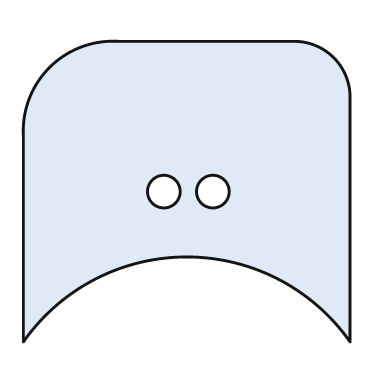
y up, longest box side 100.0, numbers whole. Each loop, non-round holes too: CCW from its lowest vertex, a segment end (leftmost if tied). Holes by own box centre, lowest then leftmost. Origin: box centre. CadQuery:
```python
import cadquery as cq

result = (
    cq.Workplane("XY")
    .moveTo(-50.0, -46.0)
    .threePointArc((0.0, -20.0), (50.0, -46.0))
    .lineTo(50.0, 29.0)
    .threePointArc((45.0, 41.0), (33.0, 46.0))
    .lineTo(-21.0, 46.0)
    .threePointArc((-42.0, 38.0), (-50.0, 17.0))
    .close()
    .moveTo(-7.0, 0.0)
    .circle(5.0)
    .moveTo(8.0, 0.0)
    .circle(5.0)
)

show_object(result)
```